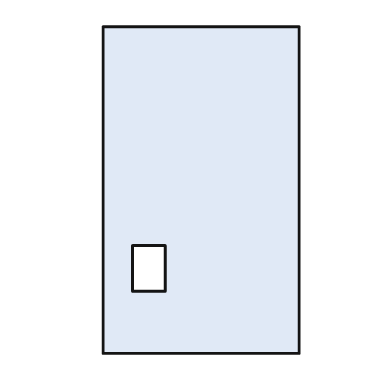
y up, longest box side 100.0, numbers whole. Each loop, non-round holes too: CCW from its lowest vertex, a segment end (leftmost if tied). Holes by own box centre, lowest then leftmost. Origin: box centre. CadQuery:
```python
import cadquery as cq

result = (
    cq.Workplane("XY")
    .moveTo(-30.0, -50.0)
    .lineTo(30.0, -50.0)
    .lineTo(30.0, 50.0)
    .lineTo(-30.0, 50.0)
    .close()
    .moveTo(-21.0, -31.0)
    .lineTo(-11.0, -31.0)
    .lineTo(-11.0, -17.0)
    .lineTo(-21.0, -17.0)
    .close()
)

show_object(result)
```